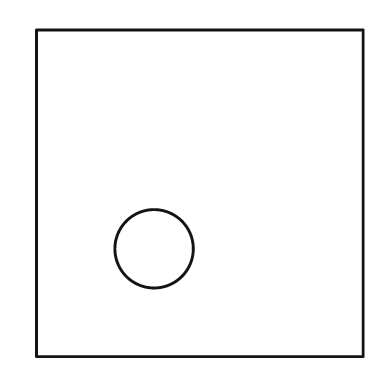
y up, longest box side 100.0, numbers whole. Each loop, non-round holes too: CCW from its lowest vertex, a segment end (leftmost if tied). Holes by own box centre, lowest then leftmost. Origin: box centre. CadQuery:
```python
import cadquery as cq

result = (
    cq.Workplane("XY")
    .moveTo(-50.0, -50.0)
    .lineTo(50.0, -50.0)
    .lineTo(50.0, 50.0)
    .lineTo(-50.0, 50.0)
    .close()
    .moveTo(-14.0, -17.0)
    .circle(12.0)
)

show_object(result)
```